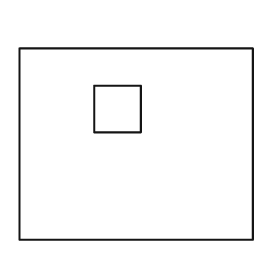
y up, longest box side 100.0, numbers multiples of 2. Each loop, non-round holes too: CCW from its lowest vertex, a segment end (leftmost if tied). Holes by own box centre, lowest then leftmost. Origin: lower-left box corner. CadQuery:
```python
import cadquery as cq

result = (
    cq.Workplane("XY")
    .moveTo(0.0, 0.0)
    .lineTo(100.0, 0.0)
    .lineTo(100.0, 82.0)
    .lineTo(0.0, 82.0)
    .close()
    .moveTo(32.0, 46.0)
    .lineTo(52.0, 46.0)
    .lineTo(52.0, 66.0)
    .lineTo(32.0, 66.0)
    .close()
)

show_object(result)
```